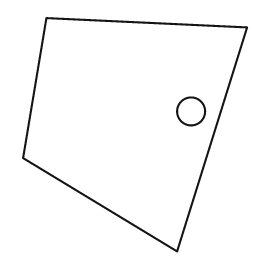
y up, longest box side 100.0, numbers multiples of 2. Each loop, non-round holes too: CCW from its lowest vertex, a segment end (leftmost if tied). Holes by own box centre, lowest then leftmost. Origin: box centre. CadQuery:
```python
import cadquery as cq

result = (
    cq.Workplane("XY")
    .moveTo(18.0, -50.0)
    .lineTo(48.0, 46.0)
    .lineTo(-38.0, 50.0)
    .lineTo(-48.0, -10.0)
    .close()
    .moveTo(24.0, 10.0)
    .circle(6.0)
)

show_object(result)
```